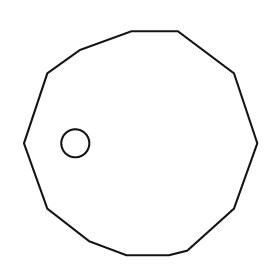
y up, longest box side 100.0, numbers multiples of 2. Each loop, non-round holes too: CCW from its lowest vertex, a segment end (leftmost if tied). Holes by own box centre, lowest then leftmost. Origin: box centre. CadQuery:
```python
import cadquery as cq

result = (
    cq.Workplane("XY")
    .moveTo(-6.0, -48.0)
    .lineTo(12.0, -48.0)
    .lineTo(20.0, -46.0)
    .lineTo(40.0, -28.0)
    .lineTo(50.0, 0.0)
    .lineTo(40.0, 30.0)
    .lineTo(16.0, 48.0)
    .lineTo(-4.0, 48.0)
    .lineTo(-26.0, 40.0)
    .lineTo(-40.0, 30.0)
    .lineTo(-50.0, 0.0)
    .lineTo(-40.0, -28.0)
    .lineTo(-22.0, -42.0)
    .close()
    .moveTo(-28.0, 0.0)
    .circle(6.0)
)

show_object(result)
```